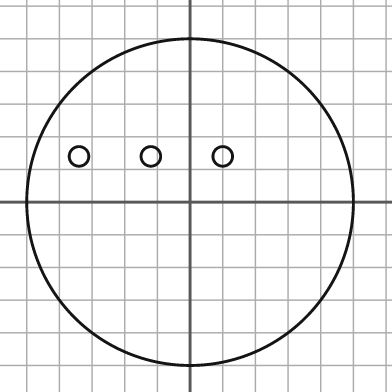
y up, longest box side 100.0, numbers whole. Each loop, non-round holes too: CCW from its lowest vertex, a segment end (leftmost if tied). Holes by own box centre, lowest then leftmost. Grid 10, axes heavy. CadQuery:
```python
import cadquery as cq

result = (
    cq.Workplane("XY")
    .moveTo(0.0, 0.0)
    .circle(50.0)
    .moveTo(-34.0, 14.0)
    .circle(3.0)
    .moveTo(-12.0, 14.0)
    .circle(3.0)
    .moveTo(10.0, 14.0)
    .circle(3.0)
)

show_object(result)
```